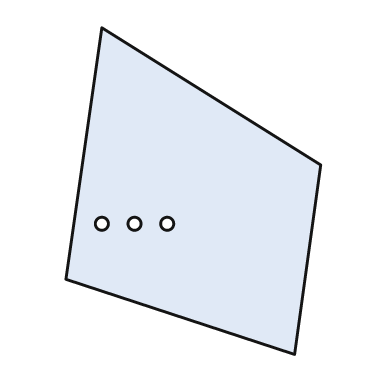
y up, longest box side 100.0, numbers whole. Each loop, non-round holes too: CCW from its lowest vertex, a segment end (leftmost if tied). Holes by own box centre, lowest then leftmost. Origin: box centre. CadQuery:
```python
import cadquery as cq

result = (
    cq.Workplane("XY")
    .moveTo(31.0, -50.0)
    .lineTo(39.0, 8.0)
    .lineTo(-28.0, 50.0)
    .lineTo(-39.0, -27.0)
    .close()
    .moveTo(-28.0, -10.0)
    .circle(2.0)
    .moveTo(-18.0, -10.0)
    .circle(2.0)
    .moveTo(-8.0, -10.0)
    .circle(2.0)
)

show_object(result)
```